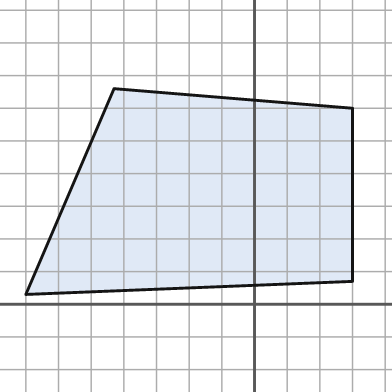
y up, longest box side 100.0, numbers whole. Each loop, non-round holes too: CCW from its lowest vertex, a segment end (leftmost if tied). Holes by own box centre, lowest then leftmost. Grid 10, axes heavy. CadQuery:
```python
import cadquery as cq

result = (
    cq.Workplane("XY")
    .moveTo(-70.0, 3.0)
    .lineTo(30.0, 7.0)
    .lineTo(30.0, 60.0)
    .lineTo(-43.0, 66.0)
    .close()
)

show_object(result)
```